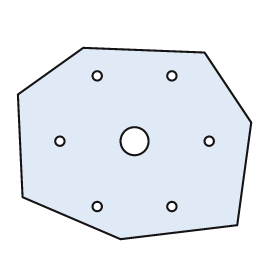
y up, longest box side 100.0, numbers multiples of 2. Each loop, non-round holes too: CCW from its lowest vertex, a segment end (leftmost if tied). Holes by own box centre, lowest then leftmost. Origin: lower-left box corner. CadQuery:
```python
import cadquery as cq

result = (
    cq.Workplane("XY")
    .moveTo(44.0, 0.0)
    .lineTo(94.0, 6.0)
    .lineTo(100.0, 50.0)
    .lineTo(80.0, 80.0)
    .lineTo(28.0, 82.0)
    .lineTo(0.0, 62.0)
    .lineTo(2.0, 18.0)
    .close()
    .moveTo(34.0, 14.0)
    .circle(2.0)
    .moveTo(66.0, 14.0)
    .circle(2.0)
    .moveTo(18.0, 42.0)
    .circle(2.0)
    .moveTo(50.0, 42.0)
    .circle(6.0)
    .moveTo(82.0, 42.0)
    .circle(2.0)
    .moveTo(34.0, 70.0)
    .circle(2.0)
    .moveTo(66.0, 70.0)
    .circle(2.0)
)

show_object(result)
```